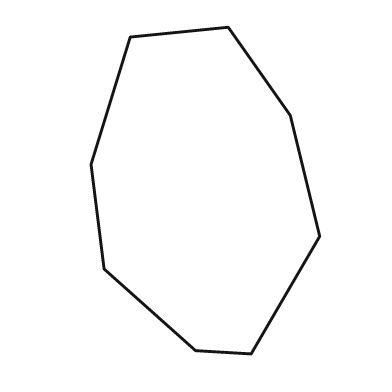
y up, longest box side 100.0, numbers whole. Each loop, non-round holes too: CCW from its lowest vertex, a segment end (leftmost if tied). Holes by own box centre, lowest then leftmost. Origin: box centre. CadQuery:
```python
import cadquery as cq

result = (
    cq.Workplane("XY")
    .moveTo(14.0, -50.0)
    .lineTo(35.0, -14.0)
    .lineTo(26.0, 23.0)
    .lineTo(7.0, 50.0)
    .lineTo(-23.0, 47.0)
    .lineTo(-35.0, 8.0)
    .lineTo(-31.0, -24.0)
    .lineTo(-3.0, -49.0)
    .close()
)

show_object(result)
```